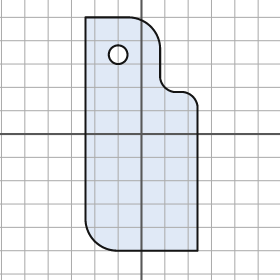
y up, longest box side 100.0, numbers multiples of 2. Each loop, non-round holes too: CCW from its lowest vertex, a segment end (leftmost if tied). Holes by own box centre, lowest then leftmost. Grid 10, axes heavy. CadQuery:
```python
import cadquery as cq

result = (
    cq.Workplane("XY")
    .moveTo(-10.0, -50.0)
    .lineTo(24.0, -50.0)
    .lineTo(24.0, 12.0)
    .threePointArc((22.0, 16.0), (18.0, 18.0))
    .lineTo(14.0, 18.0)
    .threePointArc((10.0, 20.0), (8.0, 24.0))
    .lineTo(8.0, 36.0)
    .threePointArc((4.0, 46.0), (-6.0, 50.0))
    .lineTo(-24.0, 50.0)
    .lineTo(-24.0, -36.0)
    .threePointArc((-20.0, -46.0), (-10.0, -50.0))
    .close()
    .moveTo(-10.0, 34.0)
    .circle(4.0)
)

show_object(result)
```